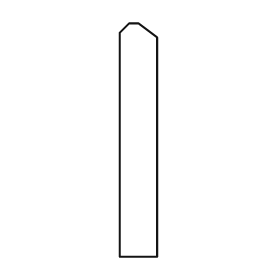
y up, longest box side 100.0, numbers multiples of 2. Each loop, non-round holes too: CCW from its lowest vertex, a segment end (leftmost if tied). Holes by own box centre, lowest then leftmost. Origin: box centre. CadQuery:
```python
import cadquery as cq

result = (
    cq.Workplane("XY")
    .moveTo(-8.0, -50.0)
    .lineTo(8.0, -50.0)
    .lineTo(8.0, 44.0)
    .lineTo(0.0, 50.0)
    .lineTo(-4.0, 50.0)
    .lineTo(-8.0, 46.0)
    .close()
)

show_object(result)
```